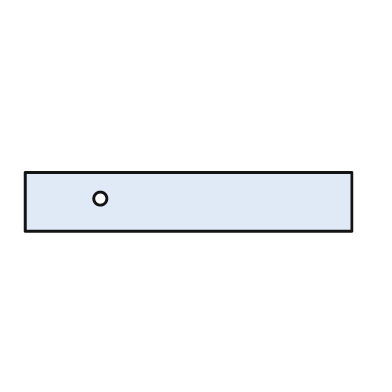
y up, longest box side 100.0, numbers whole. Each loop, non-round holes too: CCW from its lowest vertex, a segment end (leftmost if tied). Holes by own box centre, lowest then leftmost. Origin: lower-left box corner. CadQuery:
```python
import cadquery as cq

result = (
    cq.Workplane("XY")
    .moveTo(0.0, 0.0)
    .lineTo(100.0, 0.0)
    .lineTo(100.0, 18.0)
    .lineTo(0.0, 18.0)
    .close()
    .moveTo(23.0, 10.0)
    .circle(2.0)
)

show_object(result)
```